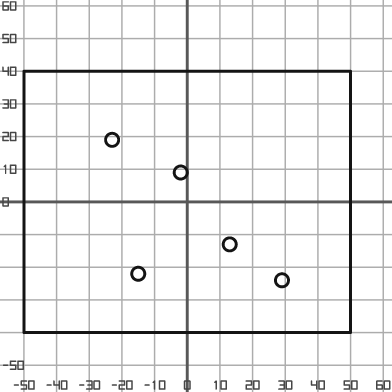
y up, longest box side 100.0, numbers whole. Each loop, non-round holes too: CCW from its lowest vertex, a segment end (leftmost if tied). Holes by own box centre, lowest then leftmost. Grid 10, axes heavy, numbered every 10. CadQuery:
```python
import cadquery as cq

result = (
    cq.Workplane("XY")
    .moveTo(-50.0, -40.0)
    .lineTo(50.0, -40.0)
    .lineTo(50.0, 40.0)
    .lineTo(-50.0, 40.0)
    .close()
    .moveTo(29.0, -24.0)
    .circle(2.0)
    .moveTo(-15.0, -22.0)
    .circle(2.0)
    .moveTo(13.0, -13.0)
    .circle(2.0)
    .moveTo(-2.0, 9.0)
    .circle(2.0)
    .moveTo(-23.0, 19.0)
    .circle(2.0)
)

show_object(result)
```